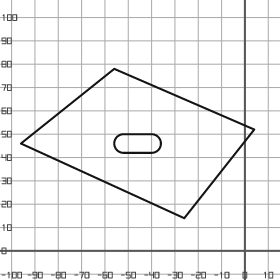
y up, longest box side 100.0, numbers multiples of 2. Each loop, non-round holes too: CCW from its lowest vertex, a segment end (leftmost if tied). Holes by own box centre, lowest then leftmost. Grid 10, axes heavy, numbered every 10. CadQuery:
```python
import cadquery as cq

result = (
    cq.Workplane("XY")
    .moveTo(-26.0, 14.0)
    .lineTo(4.0, 52.0)
    .lineTo(-56.0, 78.0)
    .lineTo(-96.0, 46.0)
    .close()
    .moveTo(-52.0, 42.0)
    .lineTo(-40.0, 42.0)
    .threePointArc((-36.0, 46.0), (-40.0, 50.0))
    .lineTo(-52.0, 50.0)
    .threePointArc((-56.0, 46.0), (-52.0, 42.0))
    .close()
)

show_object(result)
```